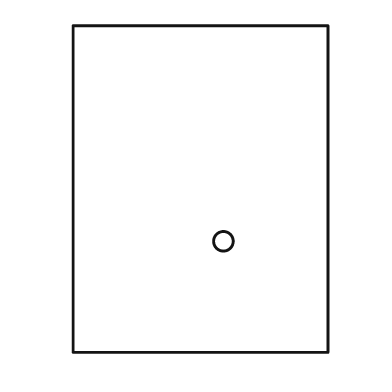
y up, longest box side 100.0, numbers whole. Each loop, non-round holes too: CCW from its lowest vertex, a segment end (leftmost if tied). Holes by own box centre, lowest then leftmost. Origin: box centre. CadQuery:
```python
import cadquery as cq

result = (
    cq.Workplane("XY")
    .moveTo(-39.0, -50.0)
    .lineTo(39.0, -50.0)
    .lineTo(39.0, 50.0)
    .lineTo(-39.0, 50.0)
    .close()
    .moveTo(7.0, -16.0)
    .circle(3.0)
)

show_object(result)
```